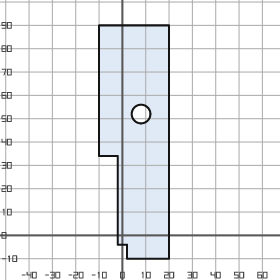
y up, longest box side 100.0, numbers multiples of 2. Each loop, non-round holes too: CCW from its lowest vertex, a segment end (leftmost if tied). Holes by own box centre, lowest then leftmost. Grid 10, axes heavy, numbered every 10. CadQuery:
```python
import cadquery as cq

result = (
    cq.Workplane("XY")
    .moveTo(2.0, -10.0)
    .lineTo(20.0, -10.0)
    .lineTo(20.0, 90.0)
    .lineTo(-10.0, 90.0)
    .lineTo(-10.0, 34.0)
    .lineTo(-2.0, 34.0)
    .lineTo(-2.0, -4.0)
    .lineTo(2.0, -4.0)
    .close()
    .moveTo(8.0, 52.0)
    .circle(4.0)
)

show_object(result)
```